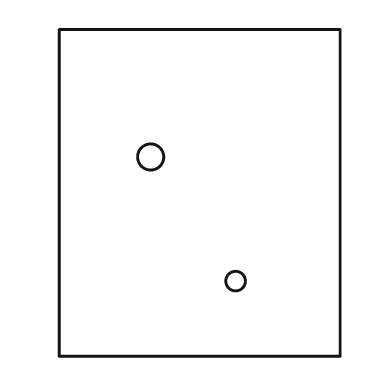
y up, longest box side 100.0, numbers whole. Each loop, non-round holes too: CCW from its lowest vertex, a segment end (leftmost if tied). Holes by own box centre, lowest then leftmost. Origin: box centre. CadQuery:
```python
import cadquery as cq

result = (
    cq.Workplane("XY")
    .moveTo(-43.0, -50.0)
    .lineTo(43.0, -50.0)
    .lineTo(43.0, 50.0)
    .lineTo(-43.0, 50.0)
    .close()
    .moveTo(11.0, -27.0)
    .circle(3.0)
    .moveTo(-15.0, 11.0)
    .circle(4.0)
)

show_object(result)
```